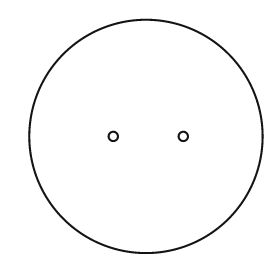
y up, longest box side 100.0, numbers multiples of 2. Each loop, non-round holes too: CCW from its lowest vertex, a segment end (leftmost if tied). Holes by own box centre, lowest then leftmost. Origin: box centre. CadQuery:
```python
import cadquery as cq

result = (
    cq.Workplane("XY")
    .moveTo(0.0, 0.0)
    .circle(50.0)
    .moveTo(-14.0, 0.0)
    .circle(2.0)
    .moveTo(16.0, 0.0)
    .circle(2.0)
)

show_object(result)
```